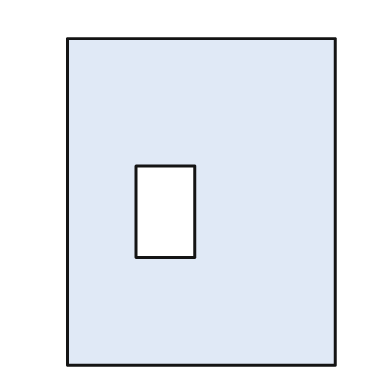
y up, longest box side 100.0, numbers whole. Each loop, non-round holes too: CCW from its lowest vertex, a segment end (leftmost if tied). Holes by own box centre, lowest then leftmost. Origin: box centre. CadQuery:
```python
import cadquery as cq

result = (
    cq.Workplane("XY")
    .moveTo(-41.0, -50.0)
    .lineTo(41.0, -50.0)
    .lineTo(41.0, 50.0)
    .lineTo(-41.0, 50.0)
    .close()
    .moveTo(-20.0, -17.0)
    .lineTo(-2.0, -17.0)
    .lineTo(-2.0, 11.0)
    .lineTo(-20.0, 11.0)
    .close()
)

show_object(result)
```